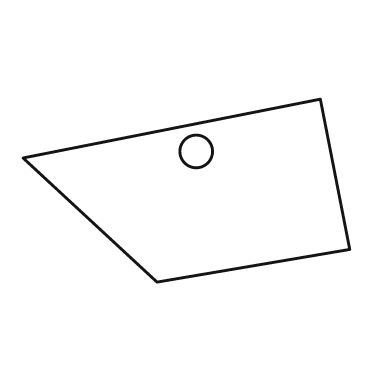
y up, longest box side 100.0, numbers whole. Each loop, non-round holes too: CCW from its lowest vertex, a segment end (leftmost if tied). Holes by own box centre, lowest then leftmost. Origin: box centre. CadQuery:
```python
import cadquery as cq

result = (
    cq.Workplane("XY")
    .moveTo(-9.0, -28.0)
    .lineTo(50.0, -18.0)
    .lineTo(41.0, 28.0)
    .lineTo(-50.0, 10.0)
    .close()
    .moveTo(3.0, 12.0)
    .circle(5.0)
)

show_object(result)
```